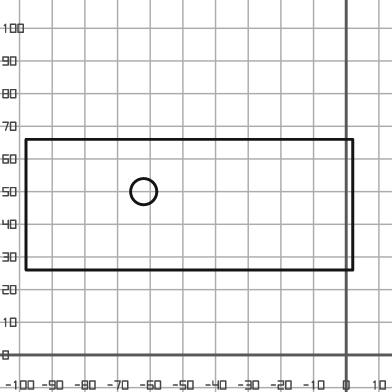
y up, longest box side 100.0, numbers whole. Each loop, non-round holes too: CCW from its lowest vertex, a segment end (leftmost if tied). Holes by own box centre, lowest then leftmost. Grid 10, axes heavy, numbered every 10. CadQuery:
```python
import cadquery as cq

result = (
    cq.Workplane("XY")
    .moveTo(-98.0, 26.0)
    .lineTo(2.0, 26.0)
    .lineTo(2.0, 66.0)
    .lineTo(-98.0, 66.0)
    .close()
    .moveTo(-62.0, 50.0)
    .circle(4.0)
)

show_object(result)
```